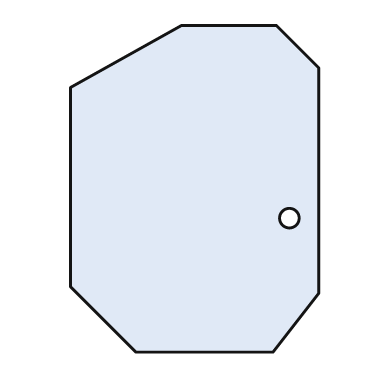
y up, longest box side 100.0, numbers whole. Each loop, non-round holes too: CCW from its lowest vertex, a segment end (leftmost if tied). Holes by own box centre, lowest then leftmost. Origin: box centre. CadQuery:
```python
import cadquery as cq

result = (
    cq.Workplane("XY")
    .moveTo(-18.0, -50.0)
    .lineTo(24.0, -50.0)
    .lineTo(38.0, -32.0)
    .lineTo(38.0, 37.0)
    .lineTo(25.0, 50.0)
    .lineTo(-4.0, 50.0)
    .lineTo(-38.0, 31.0)
    .lineTo(-38.0, -30.0)
    .close()
    .moveTo(29.0, -9.0)
    .circle(3.0)
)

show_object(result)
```